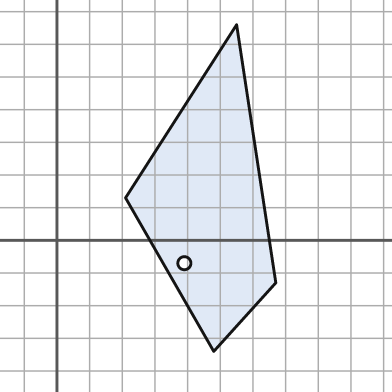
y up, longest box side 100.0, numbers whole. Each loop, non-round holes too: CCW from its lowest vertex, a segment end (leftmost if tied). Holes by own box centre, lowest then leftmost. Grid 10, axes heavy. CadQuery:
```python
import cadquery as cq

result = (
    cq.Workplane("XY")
    .moveTo(48.0, -34.0)
    .lineTo(67.0, -13.0)
    .lineTo(55.0, 66.0)
    .lineTo(21.0, 13.0)
    .close()
    .moveTo(39.0, -7.0)
    .circle(2.0)
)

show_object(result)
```